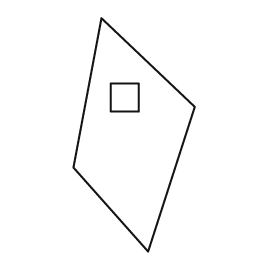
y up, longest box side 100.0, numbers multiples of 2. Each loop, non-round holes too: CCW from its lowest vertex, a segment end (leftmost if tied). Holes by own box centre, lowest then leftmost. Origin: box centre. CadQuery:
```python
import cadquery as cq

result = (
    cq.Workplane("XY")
    .moveTo(6.0, -50.0)
    .lineTo(26.0, 12.0)
    .lineTo(-14.0, 50.0)
    .lineTo(-26.0, -14.0)
    .close()
    .moveTo(-10.0, 10.0)
    .lineTo(2.0, 10.0)
    .lineTo(2.0, 22.0)
    .lineTo(-10.0, 22.0)
    .close()
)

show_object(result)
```